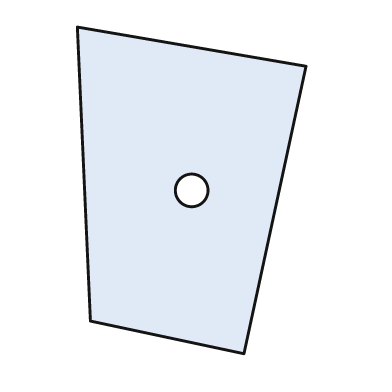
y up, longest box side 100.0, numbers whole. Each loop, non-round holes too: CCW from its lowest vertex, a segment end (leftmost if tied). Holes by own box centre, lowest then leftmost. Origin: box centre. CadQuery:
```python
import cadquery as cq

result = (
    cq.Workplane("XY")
    .moveTo(16.0, -50.0)
    .lineTo(35.0, 38.0)
    .lineTo(-35.0, 50.0)
    .lineTo(-31.0, -40.0)
    .close()
    .moveTo(0.0, 0.0)
    .circle(5.0)
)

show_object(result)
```